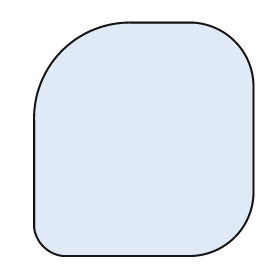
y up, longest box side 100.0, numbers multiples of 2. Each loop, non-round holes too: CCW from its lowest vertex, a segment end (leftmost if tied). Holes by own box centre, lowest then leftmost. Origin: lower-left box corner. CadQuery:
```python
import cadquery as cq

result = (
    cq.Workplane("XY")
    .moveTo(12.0, 0.0)
    .lineTo(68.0, 0.0)
    .threePointArc((86.0, 8.0), (94.0, 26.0))
    .lineTo(94.0, 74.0)
    .threePointArc((86.0, 92.0), (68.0, 100.0))
    .lineTo(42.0, 100.0)
    .threePointArc((12.0, 88.0), (0.0, 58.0))
    .lineTo(0.0, 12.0)
    .threePointArc((4.0, 4.0), (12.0, 0.0))
    .close()
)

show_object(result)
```